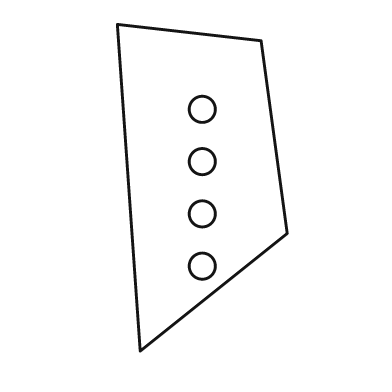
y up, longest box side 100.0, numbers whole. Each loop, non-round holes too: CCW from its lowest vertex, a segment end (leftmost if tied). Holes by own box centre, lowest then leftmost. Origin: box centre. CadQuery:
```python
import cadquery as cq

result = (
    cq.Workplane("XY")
    .moveTo(-19.0, -50.0)
    .lineTo(26.0, -14.0)
    .lineTo(18.0, 45.0)
    .lineTo(-26.0, 50.0)
    .close()
    .moveTo(0.0, -24.0)
    .circle(4.0)
    .moveTo(0.0, -8.0)
    .circle(4.0)
    .moveTo(0.0, 8.0)
    .circle(4.0)
    .moveTo(0.0, 24.0)
    .circle(4.0)
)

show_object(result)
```